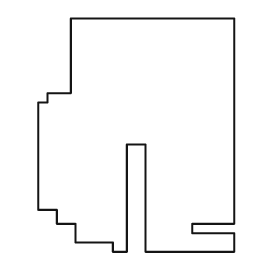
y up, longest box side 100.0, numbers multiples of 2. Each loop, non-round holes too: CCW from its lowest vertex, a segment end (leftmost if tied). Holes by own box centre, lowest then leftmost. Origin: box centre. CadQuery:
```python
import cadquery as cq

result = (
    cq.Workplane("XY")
    .moveTo(-10.0, -50.0)
    .lineTo(-4.0, -50.0)
    .lineTo(-4.0, -4.0)
    .lineTo(4.0, -4.0)
    .lineTo(4.0, -50.0)
    .lineTo(42.0, -50.0)
    .lineTo(42.0, -42.0)
    .lineTo(24.0, -42.0)
    .lineTo(24.0, -38.0)
    .lineTo(42.0, -38.0)
    .lineTo(42.0, 50.0)
    .lineTo(-28.0, 50.0)
    .lineTo(-28.0, 18.0)
    .lineTo(-38.0, 18.0)
    .lineTo(-38.0, 14.0)
    .lineTo(-42.0, 14.0)
    .lineTo(-42.0, -32.0)
    .lineTo(-34.0, -32.0)
    .lineTo(-34.0, -38.0)
    .lineTo(-26.0, -38.0)
    .lineTo(-26.0, -46.0)
    .lineTo(-10.0, -46.0)
    .close()
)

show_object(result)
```